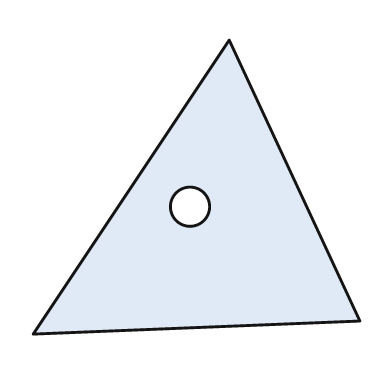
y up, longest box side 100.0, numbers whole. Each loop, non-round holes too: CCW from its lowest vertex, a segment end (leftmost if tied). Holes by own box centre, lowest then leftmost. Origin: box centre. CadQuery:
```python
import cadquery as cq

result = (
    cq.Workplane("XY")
    .moveTo(-50.0, -45.0)
    .lineTo(50.0, -41.0)
    .lineTo(10.0, 45.0)
    .close()
    .moveTo(-2.0, -6.0)
    .circle(6.0)
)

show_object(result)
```